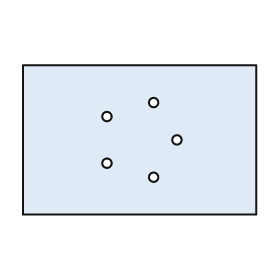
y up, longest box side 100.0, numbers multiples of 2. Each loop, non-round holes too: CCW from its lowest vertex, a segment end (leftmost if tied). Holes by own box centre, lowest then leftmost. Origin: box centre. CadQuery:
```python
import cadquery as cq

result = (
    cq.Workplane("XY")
    .moveTo(-50.0, -32.0)
    .lineTo(50.0, -32.0)
    .lineTo(50.0, 32.0)
    .lineTo(-50.0, 32.0)
    .close()
    .moveTo(6.0, -16.0)
    .circle(2.0)
    .moveTo(-14.0, -10.0)
    .circle(2.0)
    .moveTo(16.0, 0.0)
    .circle(2.0)
    .moveTo(-14.0, 10.0)
    .circle(2.0)
    .moveTo(6.0, 16.0)
    .circle(2.0)
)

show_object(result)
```